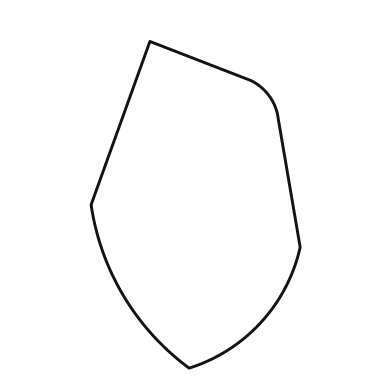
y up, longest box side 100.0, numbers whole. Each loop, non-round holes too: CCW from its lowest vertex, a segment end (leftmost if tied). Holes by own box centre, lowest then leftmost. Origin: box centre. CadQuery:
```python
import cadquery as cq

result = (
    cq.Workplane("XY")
    .moveTo(-2.0, -50.0)
    .threePointArc((20.0, -36.0), (32.0, -13.0))
    .lineTo(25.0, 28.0)
    .threePointArc((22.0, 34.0), (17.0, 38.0))
    .lineTo(-14.0, 50.0)
    .lineTo(-32.0, 0.0)
    .threePointArc((-22.0, -28.0), (-2.0, -50.0))
    .close()
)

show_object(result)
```